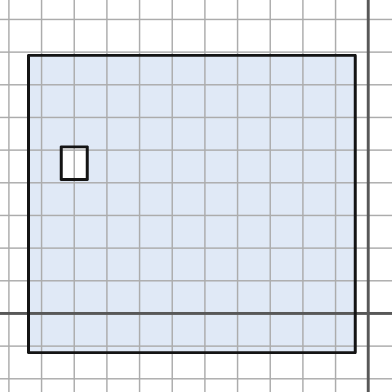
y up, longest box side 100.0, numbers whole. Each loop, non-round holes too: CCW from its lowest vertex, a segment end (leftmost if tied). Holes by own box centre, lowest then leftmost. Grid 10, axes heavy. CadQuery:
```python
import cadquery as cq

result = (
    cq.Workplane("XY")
    .moveTo(-104.0, -12.0)
    .lineTo(-4.0, -12.0)
    .lineTo(-4.0, 79.0)
    .lineTo(-104.0, 79.0)
    .close()
    .moveTo(-94.0, 41.0)
    .lineTo(-86.0, 41.0)
    .lineTo(-86.0, 51.0)
    .lineTo(-94.0, 51.0)
    .close()
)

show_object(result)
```